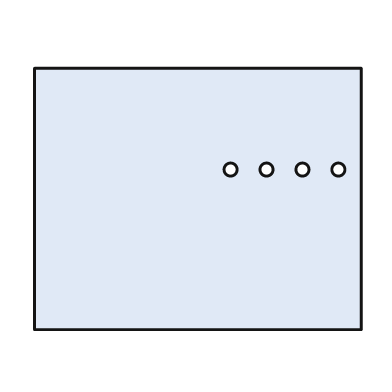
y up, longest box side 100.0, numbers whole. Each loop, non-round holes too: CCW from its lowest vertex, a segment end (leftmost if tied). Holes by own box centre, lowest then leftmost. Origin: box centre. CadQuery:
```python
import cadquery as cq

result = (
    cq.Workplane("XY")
    .moveTo(-50.0, -40.0)
    .lineTo(50.0, -40.0)
    .lineTo(50.0, 40.0)
    .lineTo(-50.0, 40.0)
    .close()
    .moveTo(10.0, 9.0)
    .circle(2.0)
    .moveTo(21.0, 9.0)
    .circle(2.0)
    .moveTo(32.0, 9.0)
    .circle(2.0)
    .moveTo(43.0, 9.0)
    .circle(2.0)
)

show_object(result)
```